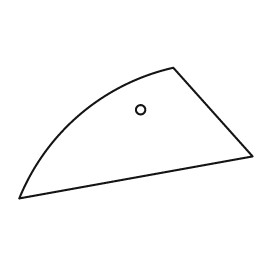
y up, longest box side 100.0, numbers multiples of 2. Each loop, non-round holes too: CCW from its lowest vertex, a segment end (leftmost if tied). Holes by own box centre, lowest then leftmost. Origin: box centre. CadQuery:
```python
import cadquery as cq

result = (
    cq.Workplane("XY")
    .moveTo(-50.0, -28.0)
    .lineTo(50.0, -10.0)
    .lineTo(16.0, 28.0)
    .threePointArc((-24.0, 8.0), (-50.0, -28.0))
    .close()
    .moveTo(2.0, 10.0)
    .circle(2.0)
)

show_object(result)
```